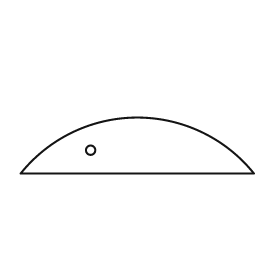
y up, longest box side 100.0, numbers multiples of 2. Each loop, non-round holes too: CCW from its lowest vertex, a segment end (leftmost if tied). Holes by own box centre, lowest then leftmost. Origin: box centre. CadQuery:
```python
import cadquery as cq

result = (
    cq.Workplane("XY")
    .moveTo(-50.0, -12.0)
    .lineTo(50.0, -12.0)
    .threePointArc((0.0, 12.0), (-50.0, -12.0))
    .close()
    .moveTo(-20.0, -2.0)
    .circle(2.0)
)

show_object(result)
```